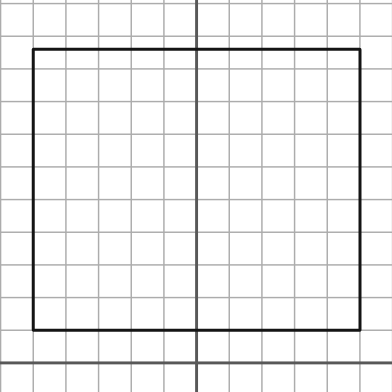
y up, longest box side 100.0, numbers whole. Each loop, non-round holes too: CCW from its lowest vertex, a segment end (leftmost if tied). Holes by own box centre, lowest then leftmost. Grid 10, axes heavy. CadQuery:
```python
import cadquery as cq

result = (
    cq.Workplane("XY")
    .moveTo(-50.0, 10.0)
    .lineTo(50.0, 10.0)
    .lineTo(50.0, 96.0)
    .lineTo(-50.0, 96.0)
    .close()
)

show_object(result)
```